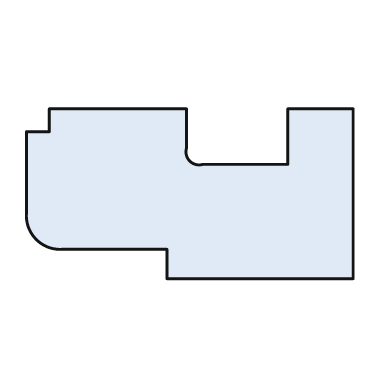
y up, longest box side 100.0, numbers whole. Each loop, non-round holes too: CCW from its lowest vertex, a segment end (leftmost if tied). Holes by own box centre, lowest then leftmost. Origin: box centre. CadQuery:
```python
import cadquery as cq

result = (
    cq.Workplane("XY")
    .moveTo(-7.0, -26.0)
    .lineTo(50.0, -26.0)
    .lineTo(50.0, 26.0)
    .lineTo(30.0, 26.0)
    .lineTo(30.0, 9.0)
    .lineTo(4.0, 9.0)
    .threePointArc((0.0, 10.0), (-1.0, 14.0))
    .lineTo(-1.0, 26.0)
    .lineTo(-43.0, 26.0)
    .lineTo(-43.0, 19.0)
    .lineTo(-50.0, 19.0)
    .lineTo(-50.0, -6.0)
    .threePointArc((-47.0, -14.0), (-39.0, -17.0))
    .lineTo(-7.0, -17.0)
    .close()
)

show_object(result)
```